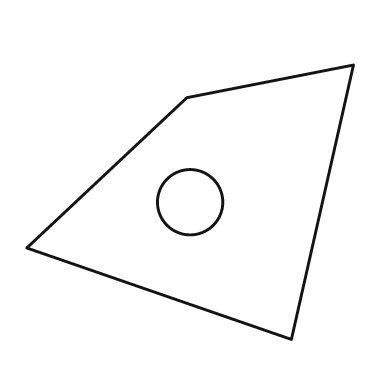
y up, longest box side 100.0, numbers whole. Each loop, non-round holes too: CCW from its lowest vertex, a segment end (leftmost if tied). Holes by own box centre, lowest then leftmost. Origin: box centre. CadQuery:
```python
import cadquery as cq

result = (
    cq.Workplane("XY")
    .moveTo(31.0, -42.0)
    .lineTo(50.0, 42.0)
    .lineTo(-1.0, 32.0)
    .lineTo(-50.0, -14.0)
    .close()
    .moveTo(0.0, 0.0)
    .circle(10.0)
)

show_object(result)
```